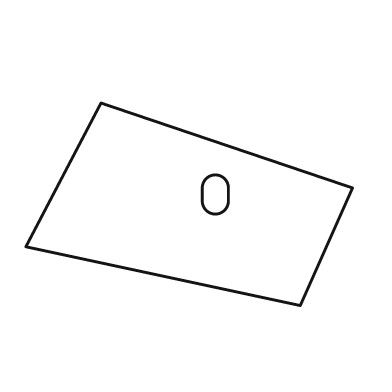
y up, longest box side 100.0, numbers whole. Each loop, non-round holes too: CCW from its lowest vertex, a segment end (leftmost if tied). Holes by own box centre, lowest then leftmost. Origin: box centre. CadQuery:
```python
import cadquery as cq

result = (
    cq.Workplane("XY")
    .moveTo(34.0, -31.0)
    .lineTo(50.0, 5.0)
    .lineTo(-27.0, 31.0)
    .lineTo(-50.0, -13.0)
    .close()
    .moveTo(4.0, 1.0)
    .threePointArc((8.0, -3.0), (12.0, 1.0))
    .lineTo(12.0, 5.0)
    .threePointArc((8.0, 9.0), (4.0, 5.0))
    .close()
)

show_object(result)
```